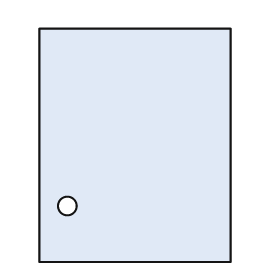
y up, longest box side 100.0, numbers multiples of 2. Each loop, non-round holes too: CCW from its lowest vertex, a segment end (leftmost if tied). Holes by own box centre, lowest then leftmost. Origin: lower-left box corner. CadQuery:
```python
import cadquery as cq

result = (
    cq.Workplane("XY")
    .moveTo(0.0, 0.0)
    .lineTo(82.0, 0.0)
    .lineTo(82.0, 100.0)
    .lineTo(0.0, 100.0)
    .close()
    .moveTo(12.0, 24.0)
    .circle(4.0)
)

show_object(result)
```